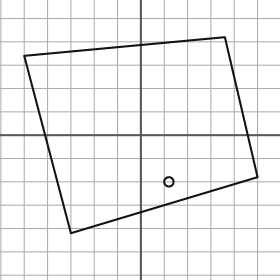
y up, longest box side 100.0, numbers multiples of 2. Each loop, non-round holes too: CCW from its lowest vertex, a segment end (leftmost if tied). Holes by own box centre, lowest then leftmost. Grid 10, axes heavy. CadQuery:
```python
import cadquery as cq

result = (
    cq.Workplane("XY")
    .moveTo(-30.0, -42.0)
    .lineTo(50.0, -18.0)
    .lineTo(36.0, 42.0)
    .lineTo(-50.0, 34.0)
    .close()
    .moveTo(12.0, -20.0)
    .circle(2.0)
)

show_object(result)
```